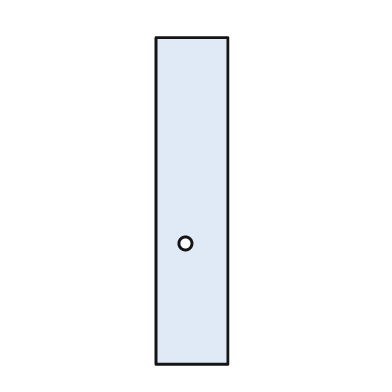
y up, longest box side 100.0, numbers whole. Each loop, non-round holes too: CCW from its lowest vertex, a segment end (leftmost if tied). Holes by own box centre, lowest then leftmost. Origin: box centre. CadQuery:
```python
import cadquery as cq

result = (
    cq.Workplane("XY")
    .moveTo(-11.0, -50.0)
    .lineTo(11.0, -50.0)
    .lineTo(11.0, 50.0)
    .lineTo(-11.0, 50.0)
    .close()
    .moveTo(-2.0, -13.0)
    .circle(2.0)
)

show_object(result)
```